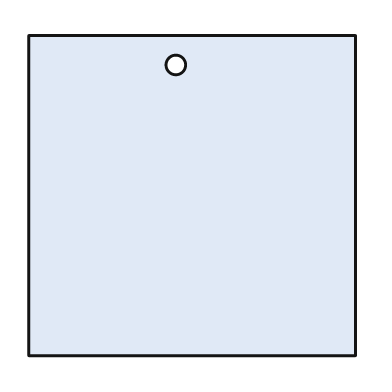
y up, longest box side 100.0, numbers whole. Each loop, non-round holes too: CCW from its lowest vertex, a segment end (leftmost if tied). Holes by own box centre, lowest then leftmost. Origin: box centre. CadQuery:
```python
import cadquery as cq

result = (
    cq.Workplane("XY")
    .moveTo(-50.0, -49.0)
    .lineTo(50.0, -49.0)
    .lineTo(50.0, 49.0)
    .lineTo(-50.0, 49.0)
    .close()
    .moveTo(-5.0, 40.0)
    .circle(3.0)
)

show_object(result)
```